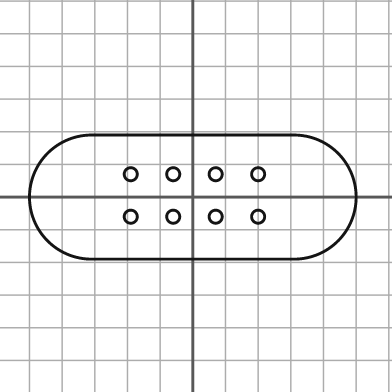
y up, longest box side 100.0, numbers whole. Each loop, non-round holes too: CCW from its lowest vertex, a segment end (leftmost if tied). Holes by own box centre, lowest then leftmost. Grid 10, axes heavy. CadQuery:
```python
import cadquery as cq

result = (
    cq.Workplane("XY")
    .moveTo(-31.0, -19.0)
    .lineTo(31.0, -19.0)
    .threePointArc((50.0, 0.0), (31.0, 19.0))
    .lineTo(-31.0, 19.0)
    .threePointArc((-50.0, 0.0), (-31.0, -19.0))
    .close()
    .moveTo(-19.0, -6.0)
    .circle(2.0)
    .moveTo(-6.0, -6.0)
    .circle(2.0)
    .moveTo(7.0, -6.0)
    .circle(2.0)
    .moveTo(20.0, -6.0)
    .circle(2.0)
    .moveTo(-19.0, 7.0)
    .circle(2.0)
    .moveTo(-6.0, 7.0)
    .circle(2.0)
    .moveTo(7.0, 7.0)
    .circle(2.0)
    .moveTo(20.0, 7.0)
    .circle(2.0)
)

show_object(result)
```